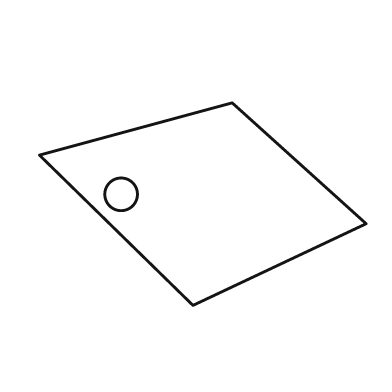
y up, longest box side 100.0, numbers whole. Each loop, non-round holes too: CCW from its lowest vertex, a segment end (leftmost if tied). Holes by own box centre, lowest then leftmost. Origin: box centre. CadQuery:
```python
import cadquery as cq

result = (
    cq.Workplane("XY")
    .moveTo(-3.0, -31.0)
    .lineTo(50.0, -6.0)
    .lineTo(9.0, 31.0)
    .lineTo(-50.0, 15.0)
    .close()
    .moveTo(-25.0, 3.0)
    .circle(5.0)
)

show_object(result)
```